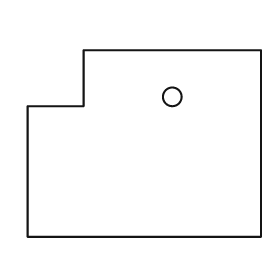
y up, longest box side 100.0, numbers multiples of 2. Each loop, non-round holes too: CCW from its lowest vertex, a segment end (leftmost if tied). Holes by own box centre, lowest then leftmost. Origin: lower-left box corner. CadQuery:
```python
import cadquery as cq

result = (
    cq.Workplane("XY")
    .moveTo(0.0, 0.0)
    .lineTo(100.0, 0.0)
    .lineTo(100.0, 80.0)
    .lineTo(24.0, 80.0)
    .lineTo(24.0, 56.0)
    .lineTo(0.0, 56.0)
    .close()
    .moveTo(62.0, 60.0)
    .circle(4.0)
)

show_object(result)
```